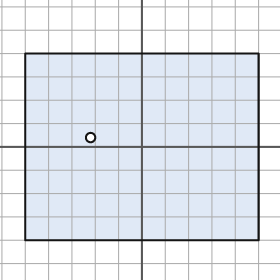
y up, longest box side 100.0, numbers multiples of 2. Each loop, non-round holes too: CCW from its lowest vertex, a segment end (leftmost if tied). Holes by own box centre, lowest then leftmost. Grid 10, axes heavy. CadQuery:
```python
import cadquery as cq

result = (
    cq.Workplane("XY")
    .moveTo(-50.0, -40.0)
    .lineTo(50.0, -40.0)
    .lineTo(50.0, 40.0)
    .lineTo(-50.0, 40.0)
    .close()
    .moveTo(-22.0, 4.0)
    .circle(2.0)
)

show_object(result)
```